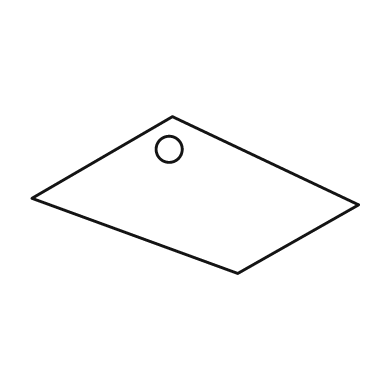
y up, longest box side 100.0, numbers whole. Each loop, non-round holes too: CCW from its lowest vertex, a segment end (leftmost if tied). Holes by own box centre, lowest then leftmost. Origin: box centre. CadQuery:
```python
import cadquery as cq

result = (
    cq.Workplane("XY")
    .moveTo(13.0, -24.0)
    .lineTo(50.0, -3.0)
    .lineTo(-7.0, 24.0)
    .lineTo(-50.0, -1.0)
    .close()
    .moveTo(-8.0, 14.0)
    .circle(4.0)
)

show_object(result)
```